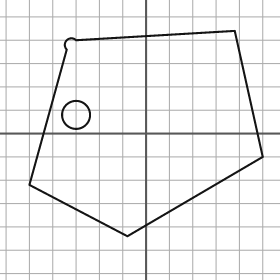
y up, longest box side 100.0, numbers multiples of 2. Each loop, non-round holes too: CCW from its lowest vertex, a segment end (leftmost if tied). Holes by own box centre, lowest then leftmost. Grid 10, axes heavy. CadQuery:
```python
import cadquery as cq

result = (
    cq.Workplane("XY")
    .moveTo(-8.0, -44.0)
    .lineTo(50.0, -10.0)
    .lineTo(38.0, 44.0)
    .lineTo(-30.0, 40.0)
    .threePointArc((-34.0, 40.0), (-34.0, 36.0))
    .lineTo(-50.0, -22.0)
    .close()
    .moveTo(-30.0, 8.0)
    .circle(6.0)
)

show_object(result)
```